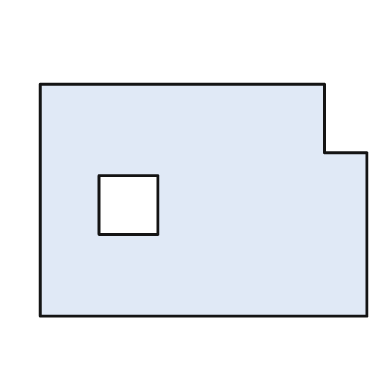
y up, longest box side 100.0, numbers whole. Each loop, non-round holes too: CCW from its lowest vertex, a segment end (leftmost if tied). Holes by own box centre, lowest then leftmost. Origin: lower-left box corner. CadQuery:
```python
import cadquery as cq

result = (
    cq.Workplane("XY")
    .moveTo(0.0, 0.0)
    .lineTo(100.0, 0.0)
    .lineTo(100.0, 50.0)
    .lineTo(87.0, 50.0)
    .lineTo(87.0, 71.0)
    .lineTo(0.0, 71.0)
    .close()
    .moveTo(18.0, 25.0)
    .lineTo(36.0, 25.0)
    .lineTo(36.0, 43.0)
    .lineTo(18.0, 43.0)
    .close()
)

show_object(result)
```